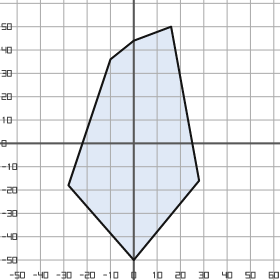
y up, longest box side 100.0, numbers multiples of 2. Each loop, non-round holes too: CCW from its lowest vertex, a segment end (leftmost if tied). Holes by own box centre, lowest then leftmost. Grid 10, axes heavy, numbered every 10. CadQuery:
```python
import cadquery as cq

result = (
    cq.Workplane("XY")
    .moveTo(0.0, -50.0)
    .lineTo(28.0, -16.0)
    .lineTo(16.0, 50.0)
    .lineTo(0.0, 44.0)
    .lineTo(-10.0, 36.0)
    .lineTo(-28.0, -18.0)
    .close()
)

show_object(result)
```